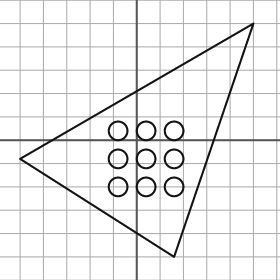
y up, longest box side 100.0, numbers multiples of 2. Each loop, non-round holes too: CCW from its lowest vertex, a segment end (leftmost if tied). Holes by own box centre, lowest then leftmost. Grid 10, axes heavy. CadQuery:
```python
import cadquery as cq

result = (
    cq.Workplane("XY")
    .moveTo(16.0, -50.0)
    .lineTo(50.0, 50.0)
    .lineTo(-50.0, -8.0)
    .close()
    .moveTo(-8.0, -20.0)
    .circle(4.0)
    .moveTo(4.0, -20.0)
    .circle(4.0)
    .moveTo(16.0, -20.0)
    .circle(4.0)
    .moveTo(-8.0, -8.0)
    .circle(4.0)
    .moveTo(4.0, -8.0)
    .circle(4.0)
    .moveTo(16.0, -8.0)
    .circle(4.0)
    .moveTo(-8.0, 4.0)
    .circle(4.0)
    .moveTo(4.0, 4.0)
    .circle(4.0)
    .moveTo(16.0, 4.0)
    .circle(4.0)
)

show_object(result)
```